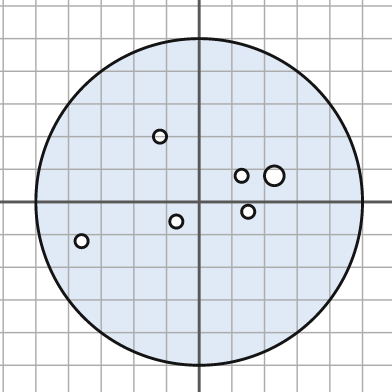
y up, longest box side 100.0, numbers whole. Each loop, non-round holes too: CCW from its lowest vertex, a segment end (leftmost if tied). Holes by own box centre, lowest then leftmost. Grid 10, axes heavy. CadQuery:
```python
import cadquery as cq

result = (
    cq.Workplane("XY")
    .moveTo(0.0, 0.0)
    .circle(50.0)
    .moveTo(-36.0, -12.0)
    .circle(2.0)
    .moveTo(-7.0, -6.0)
    .circle(2.0)
    .moveTo(15.0, -3.0)
    .circle(2.0)
    .moveTo(13.0, 8.0)
    .circle(2.0)
    .moveTo(23.0, 8.0)
    .circle(3.0)
    .moveTo(-12.0, 20.0)
    .circle(2.0)
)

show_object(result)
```